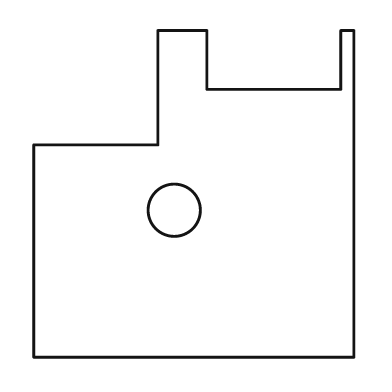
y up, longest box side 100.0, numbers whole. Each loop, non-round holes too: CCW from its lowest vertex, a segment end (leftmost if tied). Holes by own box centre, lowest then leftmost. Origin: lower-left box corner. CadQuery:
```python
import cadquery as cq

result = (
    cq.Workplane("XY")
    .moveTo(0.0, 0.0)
    .lineTo(98.0, 0.0)
    .lineTo(98.0, 100.0)
    .lineTo(94.0, 100.0)
    .lineTo(94.0, 82.0)
    .lineTo(53.0, 82.0)
    .lineTo(53.0, 100.0)
    .lineTo(38.0, 100.0)
    .lineTo(38.0, 65.0)
    .lineTo(0.0, 65.0)
    .close()
    .moveTo(43.0, 45.0)
    .circle(8.0)
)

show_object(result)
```